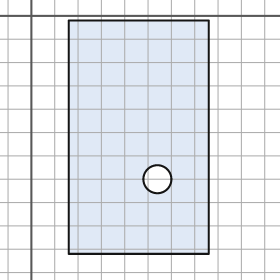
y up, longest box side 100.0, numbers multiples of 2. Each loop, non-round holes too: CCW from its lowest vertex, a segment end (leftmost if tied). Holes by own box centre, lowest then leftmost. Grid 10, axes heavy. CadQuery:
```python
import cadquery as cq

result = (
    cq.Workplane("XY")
    .moveTo(16.0, -102.0)
    .lineTo(76.0, -102.0)
    .lineTo(76.0, -2.0)
    .lineTo(16.0, -2.0)
    .close()
    .moveTo(54.0, -70.0)
    .circle(6.0)
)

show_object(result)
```